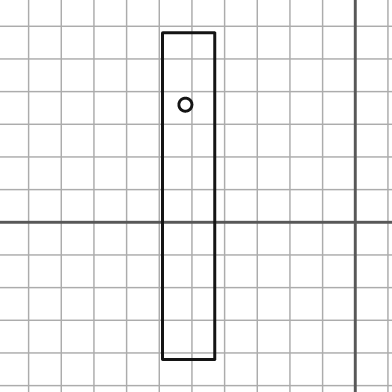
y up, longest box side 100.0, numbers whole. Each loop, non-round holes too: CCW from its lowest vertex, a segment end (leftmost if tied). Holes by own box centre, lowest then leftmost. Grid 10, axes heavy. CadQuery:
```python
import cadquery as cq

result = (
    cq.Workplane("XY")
    .moveTo(-59.0, -42.0)
    .lineTo(-43.0, -42.0)
    .lineTo(-43.0, 58.0)
    .lineTo(-59.0, 58.0)
    .close()
    .moveTo(-52.0, 36.0)
    .circle(2.0)
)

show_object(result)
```